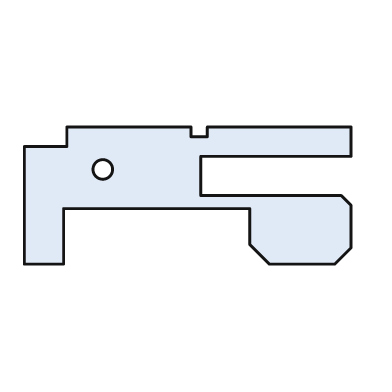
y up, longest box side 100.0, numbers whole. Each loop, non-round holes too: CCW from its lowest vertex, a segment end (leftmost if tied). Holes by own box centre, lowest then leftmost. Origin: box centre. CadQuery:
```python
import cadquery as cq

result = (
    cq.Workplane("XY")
    .moveTo(-50.0, -21.0)
    .lineTo(-38.0, -21.0)
    .lineTo(-38.0, -4.0)
    .lineTo(19.0, -4.0)
    .lineTo(19.0, -15.0)
    .lineTo(25.0, -21.0)
    .lineTo(45.0, -21.0)
    .lineTo(50.0, -16.0)
    .lineTo(50.0, -3.0)
    .lineTo(47.0, 0.0)
    .lineTo(4.0, 0.0)
    .lineTo(4.0, 12.0)
    .lineTo(50.0, 12.0)
    .lineTo(50.0, 21.0)
    .lineTo(6.0, 21.0)
    .lineTo(6.0, 18.0)
    .lineTo(1.0, 18.0)
    .lineTo(1.0, 21.0)
    .lineTo(-37.0, 21.0)
    .lineTo(-37.0, 15.0)
    .lineTo(-50.0, 15.0)
    .close()
    .moveTo(-26.0, 8.0)
    .circle(3.0)
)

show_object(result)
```